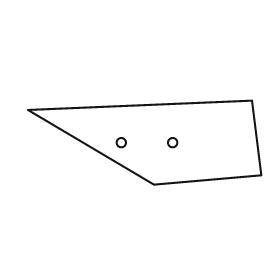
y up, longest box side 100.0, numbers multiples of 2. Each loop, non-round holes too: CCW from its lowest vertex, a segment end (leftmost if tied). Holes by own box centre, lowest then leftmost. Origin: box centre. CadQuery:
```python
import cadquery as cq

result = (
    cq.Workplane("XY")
    .moveTo(4.0, -18.0)
    .lineTo(50.0, -14.0)
    .lineTo(46.0, 18.0)
    .lineTo(-50.0, 14.0)
    .close()
    .moveTo(-10.0, 0.0)
    .circle(2.0)
    .moveTo(12.0, 0.0)
    .circle(2.0)
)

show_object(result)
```